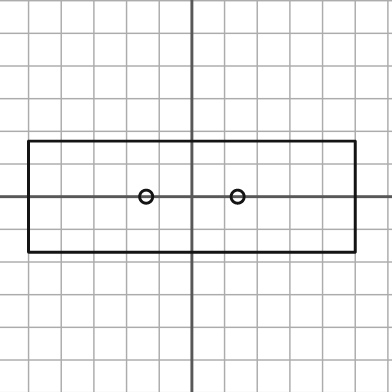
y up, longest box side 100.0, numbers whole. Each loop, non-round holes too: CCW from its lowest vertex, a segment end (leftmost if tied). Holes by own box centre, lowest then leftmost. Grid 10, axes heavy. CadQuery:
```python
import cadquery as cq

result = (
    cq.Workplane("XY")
    .moveTo(-50.0, -17.0)
    .lineTo(50.0, -17.0)
    .lineTo(50.0, 17.0)
    .lineTo(-50.0, 17.0)
    .close()
    .moveTo(-14.0, 0.0)
    .circle(2.0)
    .moveTo(14.0, 0.0)
    .circle(2.0)
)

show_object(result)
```